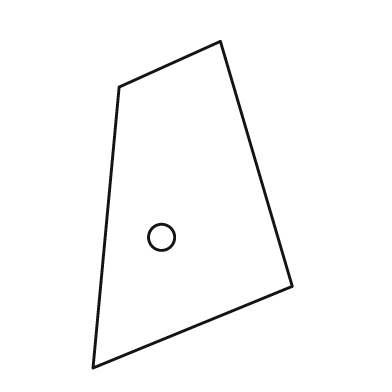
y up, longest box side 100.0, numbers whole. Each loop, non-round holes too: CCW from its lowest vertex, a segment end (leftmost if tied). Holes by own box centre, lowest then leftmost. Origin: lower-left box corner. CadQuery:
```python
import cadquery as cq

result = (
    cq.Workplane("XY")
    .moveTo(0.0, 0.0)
    .lineTo(61.0, 25.0)
    .lineTo(39.0, 100.0)
    .lineTo(8.0, 86.0)
    .close()
    .moveTo(21.0, 40.0)
    .circle(4.0)
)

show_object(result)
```